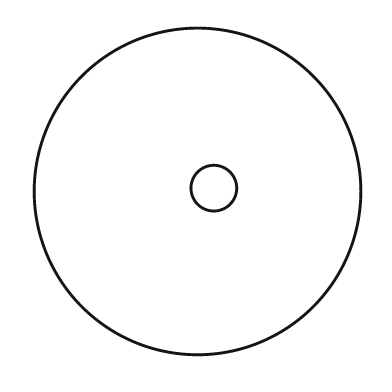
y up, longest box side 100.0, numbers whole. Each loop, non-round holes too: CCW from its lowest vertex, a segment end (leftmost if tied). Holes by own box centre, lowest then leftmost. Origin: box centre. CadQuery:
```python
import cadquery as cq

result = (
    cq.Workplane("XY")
    .moveTo(0.0, 0.0)
    .circle(50.0)
    .moveTo(5.0, 1.0)
    .circle(7.0)
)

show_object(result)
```